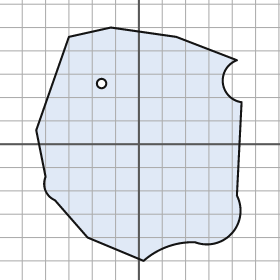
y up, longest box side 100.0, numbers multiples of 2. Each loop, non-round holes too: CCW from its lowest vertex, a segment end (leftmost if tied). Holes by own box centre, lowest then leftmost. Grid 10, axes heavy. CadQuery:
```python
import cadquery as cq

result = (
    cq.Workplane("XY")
    .moveTo(2.0, -50.0)
    .threePointArc((12.0, -44.0), (24.0, -42.0))
    .threePointArc((40.0, -38.0), (42.0, -22.0))
    .lineTo(44.0, 18.0)
    .threePointArc((36.0, 26.0), (42.0, 36.0))
    .lineTo(16.0, 46.0)
    .lineTo(-12.0, 50.0)
    .lineTo(-30.0, 46.0)
    .lineTo(-44.0, 6.0)
    .lineTo(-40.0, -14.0)
    .threePointArc((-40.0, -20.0), (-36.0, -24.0))
    .lineTo(-22.0, -40.0)
    .close()
    .moveTo(-16.0, 26.0)
    .circle(2.0)
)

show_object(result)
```